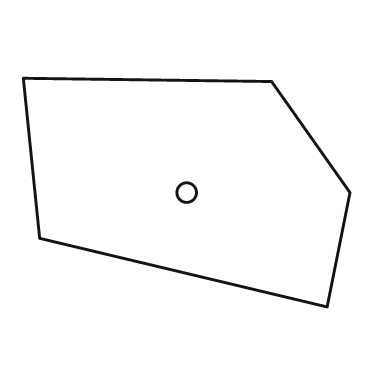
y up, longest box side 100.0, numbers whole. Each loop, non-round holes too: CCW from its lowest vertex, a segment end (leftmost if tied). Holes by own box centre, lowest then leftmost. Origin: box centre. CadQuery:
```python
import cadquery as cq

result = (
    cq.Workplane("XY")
    .moveTo(43.0, -35.0)
    .lineTo(50.0, 0.0)
    .lineTo(26.0, 34.0)
    .lineTo(-50.0, 35.0)
    .lineTo(-45.0, -14.0)
    .close()
    .moveTo(0.0, 0.0)
    .circle(3.0)
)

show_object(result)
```